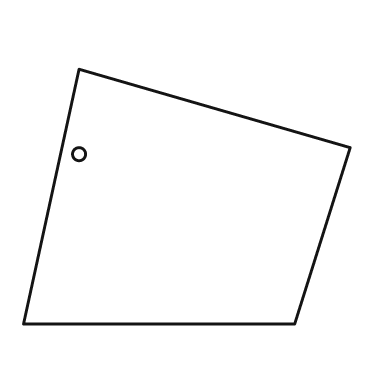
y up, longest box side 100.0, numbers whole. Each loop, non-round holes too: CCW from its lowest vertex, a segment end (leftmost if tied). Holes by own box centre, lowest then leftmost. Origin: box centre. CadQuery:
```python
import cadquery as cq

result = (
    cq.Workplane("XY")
    .moveTo(-50.0, -39.0)
    .lineTo(33.0, -39.0)
    .lineTo(50.0, 15.0)
    .lineTo(-33.0, 39.0)
    .close()
    .moveTo(-33.0, 13.0)
    .circle(2.0)
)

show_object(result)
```